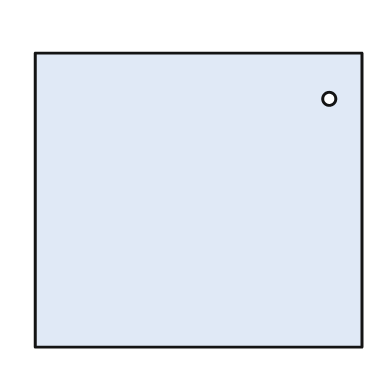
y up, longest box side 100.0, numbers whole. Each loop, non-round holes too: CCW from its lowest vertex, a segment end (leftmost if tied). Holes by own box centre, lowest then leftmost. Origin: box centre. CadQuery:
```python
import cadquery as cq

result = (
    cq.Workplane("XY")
    .moveTo(-50.0, -45.0)
    .lineTo(50.0, -45.0)
    .lineTo(50.0, 45.0)
    .lineTo(-50.0, 45.0)
    .close()
    .moveTo(40.0, 31.0)
    .circle(2.0)
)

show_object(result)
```